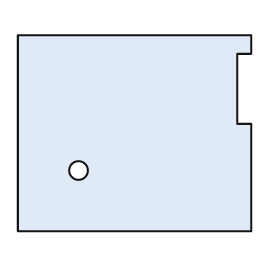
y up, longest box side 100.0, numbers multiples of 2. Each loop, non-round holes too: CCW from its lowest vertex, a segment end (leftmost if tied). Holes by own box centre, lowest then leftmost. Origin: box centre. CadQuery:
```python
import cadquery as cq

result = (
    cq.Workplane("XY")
    .moveTo(-50.0, -42.0)
    .lineTo(50.0, -42.0)
    .lineTo(50.0, 4.0)
    .lineTo(44.0, 4.0)
    .lineTo(44.0, 34.0)
    .lineTo(50.0, 34.0)
    .lineTo(50.0, 42.0)
    .lineTo(-50.0, 42.0)
    .close()
    .moveTo(-24.0, -16.0)
    .circle(4.0)
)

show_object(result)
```